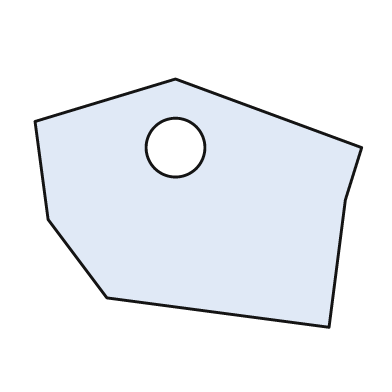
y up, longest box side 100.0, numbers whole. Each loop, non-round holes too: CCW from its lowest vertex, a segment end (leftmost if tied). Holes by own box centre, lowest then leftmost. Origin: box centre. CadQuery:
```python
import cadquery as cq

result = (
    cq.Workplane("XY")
    .moveTo(40.0, -38.0)
    .lineTo(45.0, 1.0)
    .lineTo(50.0, 17.0)
    .lineTo(-7.0, 38.0)
    .lineTo(-50.0, 25.0)
    .lineTo(-46.0, -5.0)
    .lineTo(-28.0, -29.0)
    .close()
    .moveTo(-7.0, 17.0)
    .circle(9.0)
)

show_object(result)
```